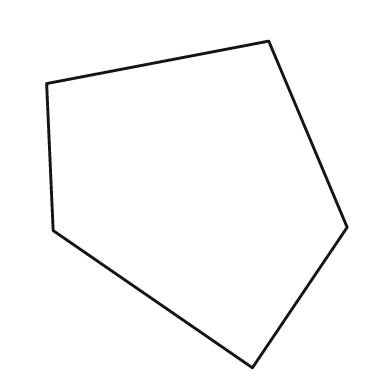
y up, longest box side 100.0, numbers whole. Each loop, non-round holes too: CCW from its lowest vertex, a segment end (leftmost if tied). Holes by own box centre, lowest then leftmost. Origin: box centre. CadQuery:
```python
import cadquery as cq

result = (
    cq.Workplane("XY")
    .moveTo(17.0, -50.0)
    .lineTo(46.0, -7.0)
    .lineTo(22.0, 50.0)
    .lineTo(-46.0, 37.0)
    .lineTo(-44.0, -8.0)
    .close()
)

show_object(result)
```